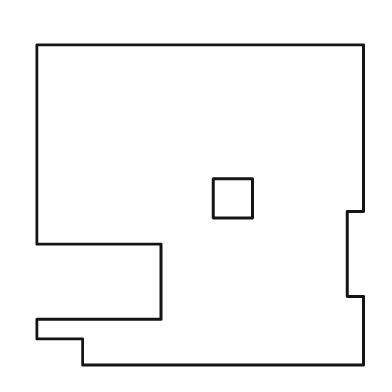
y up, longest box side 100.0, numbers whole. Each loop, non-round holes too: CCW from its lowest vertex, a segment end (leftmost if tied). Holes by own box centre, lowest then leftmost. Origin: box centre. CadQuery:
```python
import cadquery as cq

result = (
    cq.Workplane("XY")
    .moveTo(-36.0, -49.0)
    .lineTo(50.0, -49.0)
    .lineTo(50.0, -28.0)
    .lineTo(45.0, -28.0)
    .lineTo(45.0, -2.0)
    .lineTo(50.0, -2.0)
    .lineTo(50.0, 49.0)
    .lineTo(-50.0, 49.0)
    .lineTo(-50.0, -12.0)
    .lineTo(-12.0, -12.0)
    .lineTo(-12.0, -35.0)
    .lineTo(-50.0, -35.0)
    .lineTo(-50.0, -41.0)
    .lineTo(-36.0, -41.0)
    .close()
    .moveTo(4.0, -4.0)
    .lineTo(16.0, -4.0)
    .lineTo(16.0, 8.0)
    .lineTo(4.0, 8.0)
    .close()
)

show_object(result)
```